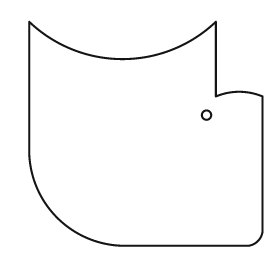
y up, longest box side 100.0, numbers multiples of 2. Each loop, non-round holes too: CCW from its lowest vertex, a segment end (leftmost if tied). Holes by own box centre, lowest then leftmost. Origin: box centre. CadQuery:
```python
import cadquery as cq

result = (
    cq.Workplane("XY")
    .moveTo(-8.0, -48.0)
    .lineTo(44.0, -48.0)
    .threePointArc((48.0, -46.0), (50.0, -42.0))
    .lineTo(50.0, 16.0)
    .threePointArc((40.0, 18.0), (30.0, 16.0))
    .lineTo(30.0, 48.0)
    .threePointArc((-10.0, 32.0), (-50.0, 48.0))
    .lineTo(-50.0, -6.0)
    .threePointArc((-38.0, -36.0), (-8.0, -48.0))
    .close()
    .moveTo(26.0, 8.0)
    .circle(2.0)
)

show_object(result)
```